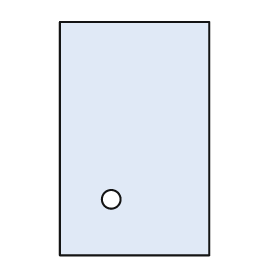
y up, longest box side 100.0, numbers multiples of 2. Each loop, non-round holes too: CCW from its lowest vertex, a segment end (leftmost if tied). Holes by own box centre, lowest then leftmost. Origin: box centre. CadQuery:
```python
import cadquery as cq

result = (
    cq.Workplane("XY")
    .moveTo(-32.0, -50.0)
    .lineTo(32.0, -50.0)
    .lineTo(32.0, 50.0)
    .lineTo(-32.0, 50.0)
    .close()
    .moveTo(-10.0, -26.0)
    .circle(4.0)
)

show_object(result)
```